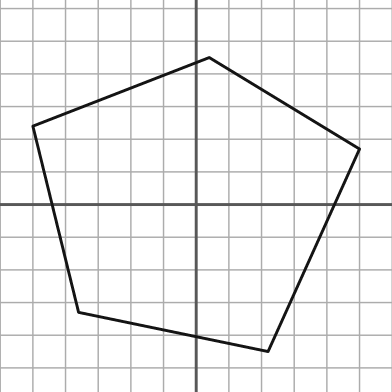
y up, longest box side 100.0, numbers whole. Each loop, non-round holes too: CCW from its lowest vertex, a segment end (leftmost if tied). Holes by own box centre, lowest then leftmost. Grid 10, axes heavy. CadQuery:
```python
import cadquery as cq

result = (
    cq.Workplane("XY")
    .moveTo(22.0, -45.0)
    .lineTo(50.0, 17.0)
    .lineTo(4.0, 45.0)
    .lineTo(-50.0, 24.0)
    .lineTo(-36.0, -33.0)
    .close()
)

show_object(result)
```